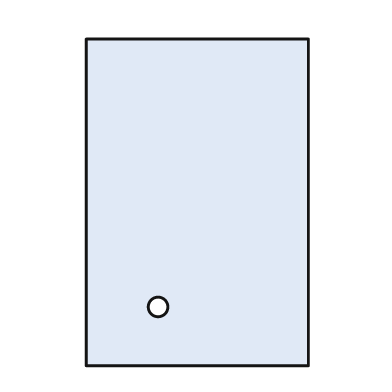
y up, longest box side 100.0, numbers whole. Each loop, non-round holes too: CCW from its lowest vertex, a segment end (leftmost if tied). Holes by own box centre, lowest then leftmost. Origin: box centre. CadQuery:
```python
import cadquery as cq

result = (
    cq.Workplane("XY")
    .moveTo(-34.0, -50.0)
    .lineTo(34.0, -50.0)
    .lineTo(34.0, 50.0)
    .lineTo(-34.0, 50.0)
    .close()
    .moveTo(-12.0, -32.0)
    .circle(3.0)
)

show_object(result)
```